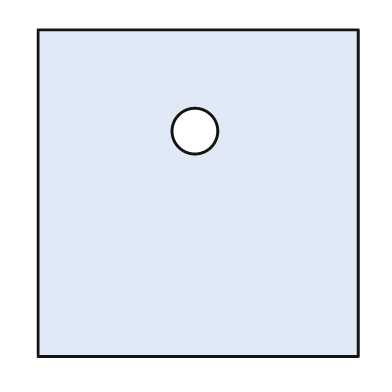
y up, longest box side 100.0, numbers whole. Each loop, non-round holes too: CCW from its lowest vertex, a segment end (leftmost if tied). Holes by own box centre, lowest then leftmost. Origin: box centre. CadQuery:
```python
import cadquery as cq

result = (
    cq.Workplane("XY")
    .moveTo(-49.0, -50.0)
    .lineTo(49.0, -50.0)
    .lineTo(49.0, 50.0)
    .lineTo(-49.0, 50.0)
    .close()
    .moveTo(-1.0, 19.0)
    .circle(7.0)
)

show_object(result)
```